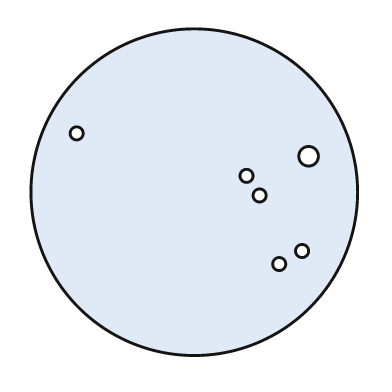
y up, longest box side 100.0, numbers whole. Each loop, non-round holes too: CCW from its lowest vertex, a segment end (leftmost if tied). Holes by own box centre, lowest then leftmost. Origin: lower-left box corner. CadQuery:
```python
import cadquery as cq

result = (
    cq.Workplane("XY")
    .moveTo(50.0, 50.0)
    .circle(50.0)
    .moveTo(76.0, 28.0)
    .circle(2.0)
    .moveTo(83.0, 32.0)
    .circle(2.0)
    .moveTo(70.0, 49.0)
    .circle(2.0)
    .moveTo(66.0, 55.0)
    .circle(2.0)
    .moveTo(85.0, 61.0)
    .circle(3.0)
    .moveTo(14.0, 68.0)
    .circle(2.0)
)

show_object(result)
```